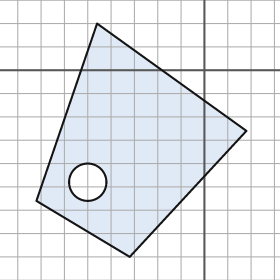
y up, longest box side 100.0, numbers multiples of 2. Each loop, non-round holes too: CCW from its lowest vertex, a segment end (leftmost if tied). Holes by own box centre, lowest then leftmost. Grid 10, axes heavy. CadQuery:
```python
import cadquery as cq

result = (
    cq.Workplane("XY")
    .moveTo(-32.0, -80.0)
    .lineTo(18.0, -26.0)
    .lineTo(-46.0, 20.0)
    .lineTo(-72.0, -56.0)
    .close()
    .moveTo(-50.0, -48.0)
    .circle(8.0)
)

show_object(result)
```